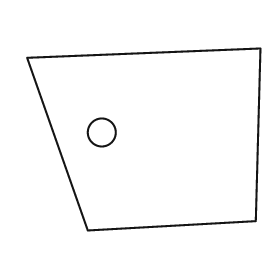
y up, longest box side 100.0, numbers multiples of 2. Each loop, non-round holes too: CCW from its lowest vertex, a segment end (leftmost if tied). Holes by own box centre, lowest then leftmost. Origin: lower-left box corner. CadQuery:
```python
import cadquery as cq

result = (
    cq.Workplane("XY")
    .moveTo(26.0, 0.0)
    .lineTo(98.0, 4.0)
    .lineTo(100.0, 78.0)
    .lineTo(0.0, 74.0)
    .close()
    .moveTo(32.0, 42.0)
    .circle(6.0)
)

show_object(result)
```